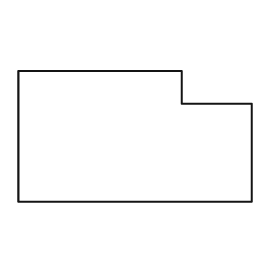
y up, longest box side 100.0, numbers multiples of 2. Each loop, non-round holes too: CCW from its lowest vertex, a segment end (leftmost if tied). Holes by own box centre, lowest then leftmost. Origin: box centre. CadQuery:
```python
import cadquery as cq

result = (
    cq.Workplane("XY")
    .moveTo(-50.0, -28.0)
    .lineTo(50.0, -28.0)
    .lineTo(50.0, 14.0)
    .lineTo(20.0, 14.0)
    .lineTo(20.0, 28.0)
    .lineTo(-50.0, 28.0)
    .close()
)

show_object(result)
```